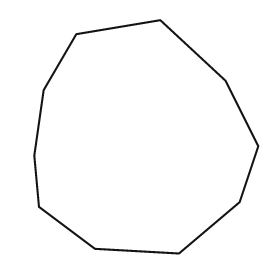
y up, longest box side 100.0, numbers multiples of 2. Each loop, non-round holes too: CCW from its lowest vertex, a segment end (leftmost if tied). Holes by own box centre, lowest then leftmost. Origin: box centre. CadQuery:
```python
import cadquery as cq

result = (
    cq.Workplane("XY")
    .moveTo(14.0, -50.0)
    .lineTo(40.0, -28.0)
    .lineTo(48.0, -4.0)
    .lineTo(34.0, 24.0)
    .lineTo(6.0, 50.0)
    .lineTo(-30.0, 44.0)
    .lineTo(-44.0, 20.0)
    .lineTo(-48.0, -8.0)
    .lineTo(-46.0, -30.0)
    .lineTo(-22.0, -48.0)
    .close()
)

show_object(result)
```